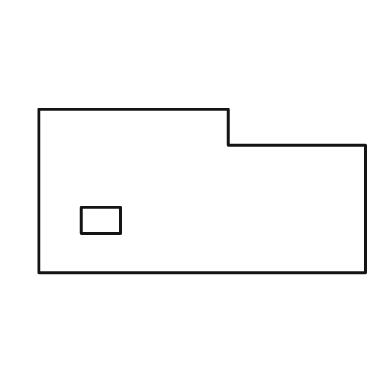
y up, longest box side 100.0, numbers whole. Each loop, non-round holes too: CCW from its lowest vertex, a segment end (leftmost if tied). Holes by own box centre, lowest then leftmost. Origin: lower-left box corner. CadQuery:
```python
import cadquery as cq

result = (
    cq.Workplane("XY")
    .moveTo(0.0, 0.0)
    .lineTo(100.0, 0.0)
    .lineTo(100.0, 39.0)
    .lineTo(58.0, 39.0)
    .lineTo(58.0, 50.0)
    .lineTo(0.0, 50.0)
    .close()
    .moveTo(13.0, 12.0)
    .lineTo(25.0, 12.0)
    .lineTo(25.0, 20.0)
    .lineTo(13.0, 20.0)
    .close()
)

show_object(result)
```